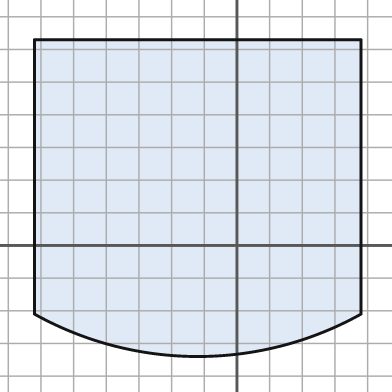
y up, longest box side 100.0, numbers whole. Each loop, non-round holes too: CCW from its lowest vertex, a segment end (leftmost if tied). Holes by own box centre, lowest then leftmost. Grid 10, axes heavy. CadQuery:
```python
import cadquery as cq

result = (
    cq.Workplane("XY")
    .moveTo(-62.0, -21.0)
    .threePointArc((-12.0, -34.0), (38.0, -21.0))
    .lineTo(38.0, 63.0)
    .lineTo(-62.0, 63.0)
    .close()
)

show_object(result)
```